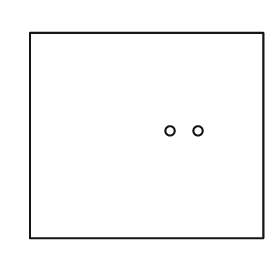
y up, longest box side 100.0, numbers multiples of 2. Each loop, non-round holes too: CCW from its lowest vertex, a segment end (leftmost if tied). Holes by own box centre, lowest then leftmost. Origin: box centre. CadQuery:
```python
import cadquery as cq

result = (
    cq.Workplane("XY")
    .moveTo(-50.0, -44.0)
    .lineTo(50.0, -44.0)
    .lineTo(50.0, 44.0)
    .lineTo(-50.0, 44.0)
    .close()
    .moveTo(10.0, 2.0)
    .circle(2.0)
    .moveTo(22.0, 2.0)
    .circle(2.0)
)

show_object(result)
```